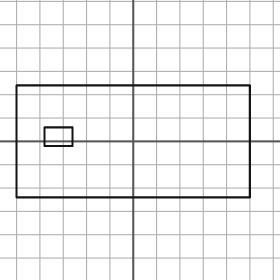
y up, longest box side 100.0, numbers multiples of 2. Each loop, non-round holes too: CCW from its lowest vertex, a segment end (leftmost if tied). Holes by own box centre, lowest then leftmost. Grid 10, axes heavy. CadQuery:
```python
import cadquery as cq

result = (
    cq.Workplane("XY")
    .moveTo(-50.0, -24.0)
    .lineTo(50.0, -24.0)
    .lineTo(50.0, 24.0)
    .lineTo(-50.0, 24.0)
    .close()
    .moveTo(-38.0, -2.0)
    .lineTo(-26.0, -2.0)
    .lineTo(-26.0, 6.0)
    .lineTo(-38.0, 6.0)
    .close()
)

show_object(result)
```